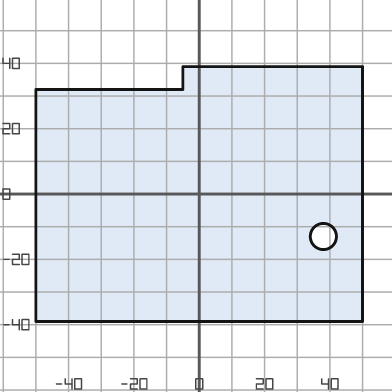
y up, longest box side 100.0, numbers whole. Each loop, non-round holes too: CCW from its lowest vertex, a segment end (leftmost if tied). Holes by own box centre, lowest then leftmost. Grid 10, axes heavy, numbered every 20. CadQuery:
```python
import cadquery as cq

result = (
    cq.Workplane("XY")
    .moveTo(-50.0, -39.0)
    .lineTo(50.0, -39.0)
    .lineTo(50.0, 39.0)
    .lineTo(-5.0, 39.0)
    .lineTo(-5.0, 32.0)
    .lineTo(-50.0, 32.0)
    .close()
    .moveTo(38.0, -13.0)
    .circle(4.0)
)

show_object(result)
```